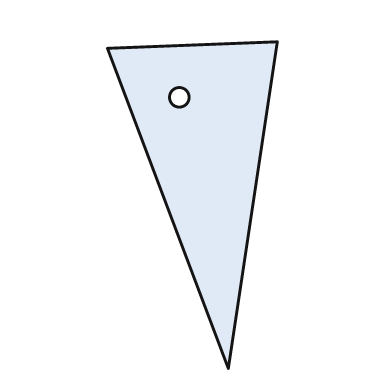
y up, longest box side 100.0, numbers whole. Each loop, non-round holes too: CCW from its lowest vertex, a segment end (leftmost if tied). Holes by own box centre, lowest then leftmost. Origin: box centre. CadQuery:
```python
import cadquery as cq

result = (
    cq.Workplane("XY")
    .moveTo(11.0, -50.0)
    .lineTo(26.0, 50.0)
    .lineTo(-26.0, 48.0)
    .close()
    .moveTo(-4.0, 33.0)
    .circle(3.0)
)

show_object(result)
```